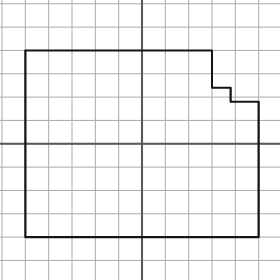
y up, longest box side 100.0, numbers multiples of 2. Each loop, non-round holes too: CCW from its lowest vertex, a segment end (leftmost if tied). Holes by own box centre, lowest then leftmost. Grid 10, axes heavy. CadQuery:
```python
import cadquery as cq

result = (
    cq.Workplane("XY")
    .moveTo(-50.0, -40.0)
    .lineTo(50.0, -40.0)
    .lineTo(50.0, 18.0)
    .lineTo(38.0, 18.0)
    .lineTo(38.0, 24.0)
    .lineTo(30.0, 24.0)
    .lineTo(30.0, 40.0)
    .lineTo(-50.0, 40.0)
    .close()
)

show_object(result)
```